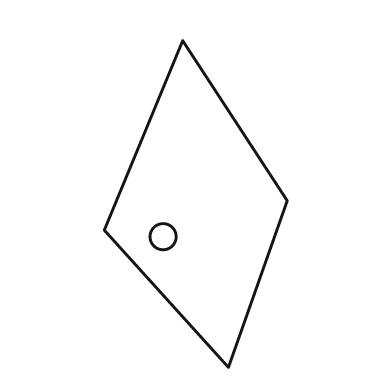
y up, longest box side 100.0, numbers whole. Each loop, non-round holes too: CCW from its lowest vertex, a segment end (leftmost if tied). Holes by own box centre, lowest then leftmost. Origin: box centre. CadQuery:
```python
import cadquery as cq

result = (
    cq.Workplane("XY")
    .moveTo(10.0, -50.0)
    .lineTo(28.0, 1.0)
    .lineTo(-4.0, 50.0)
    .lineTo(-28.0, -8.0)
    .close()
    .moveTo(-10.0, -10.0)
    .circle(4.0)
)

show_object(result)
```